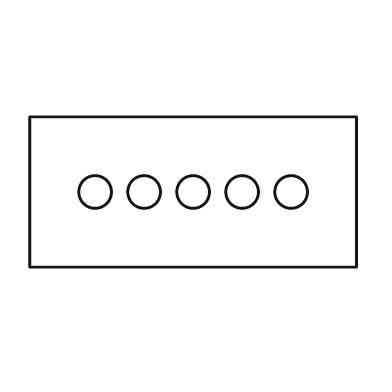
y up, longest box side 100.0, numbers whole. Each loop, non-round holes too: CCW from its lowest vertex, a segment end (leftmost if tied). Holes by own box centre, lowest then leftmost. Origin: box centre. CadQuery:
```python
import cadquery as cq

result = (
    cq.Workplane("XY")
    .moveTo(-50.0, -23.0)
    .lineTo(50.0, -23.0)
    .lineTo(50.0, 23.0)
    .lineTo(-50.0, 23.0)
    .close()
    .moveTo(-30.0, 0.0)
    .circle(5.0)
    .moveTo(-15.0, 0.0)
    .circle(5.0)
    .moveTo(0.0, 0.0)
    .circle(5.0)
    .moveTo(15.0, 0.0)
    .circle(5.0)
    .moveTo(30.0, 0.0)
    .circle(5.0)
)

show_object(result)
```